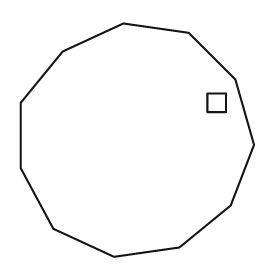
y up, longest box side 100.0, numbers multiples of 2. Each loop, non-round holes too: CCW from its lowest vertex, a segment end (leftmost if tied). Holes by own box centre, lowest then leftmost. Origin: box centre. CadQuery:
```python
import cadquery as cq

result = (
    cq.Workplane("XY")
    .moveTo(-10.0, -50.0)
    .lineTo(18.0, -46.0)
    .lineTo(40.0, -28.0)
    .lineTo(50.0, -2.0)
    .lineTo(42.0, 26.0)
    .lineTo(22.0, 46.0)
    .lineTo(-6.0, 50.0)
    .lineTo(-32.0, 38.0)
    .lineTo(-50.0, 16.0)
    .lineTo(-50.0, -12.0)
    .lineTo(-36.0, -38.0)
    .close()
    .moveTo(30.0, 12.0)
    .lineTo(38.0, 12.0)
    .lineTo(38.0, 20.0)
    .lineTo(30.0, 20.0)
    .close()
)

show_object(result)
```